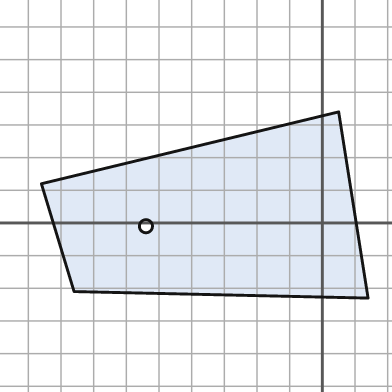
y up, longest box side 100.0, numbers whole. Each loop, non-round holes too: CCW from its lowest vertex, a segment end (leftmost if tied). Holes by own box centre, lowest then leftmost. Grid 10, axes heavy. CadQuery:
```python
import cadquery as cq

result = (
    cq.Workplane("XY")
    .moveTo(14.0, -23.0)
    .lineTo(5.0, 34.0)
    .lineTo(-86.0, 12.0)
    .lineTo(-76.0, -21.0)
    .close()
    .moveTo(-54.0, -1.0)
    .circle(2.0)
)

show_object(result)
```